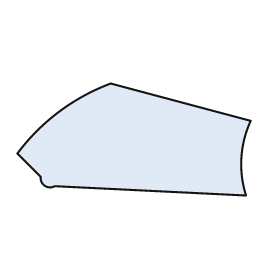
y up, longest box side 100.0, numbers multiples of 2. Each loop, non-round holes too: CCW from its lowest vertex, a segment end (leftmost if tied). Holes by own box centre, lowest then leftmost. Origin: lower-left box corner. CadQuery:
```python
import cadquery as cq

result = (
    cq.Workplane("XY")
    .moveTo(98.0, 0.0)
    .threePointArc((96.0, 16.0), (100.0, 32.0))
    .lineTo(40.0, 48.0)
    .threePointArc((18.0, 36.0), (0.0, 18.0))
    .lineTo(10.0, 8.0)
    .threePointArc((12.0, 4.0), (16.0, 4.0))
    .close()
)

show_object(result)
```